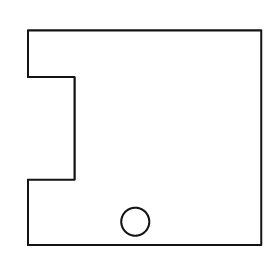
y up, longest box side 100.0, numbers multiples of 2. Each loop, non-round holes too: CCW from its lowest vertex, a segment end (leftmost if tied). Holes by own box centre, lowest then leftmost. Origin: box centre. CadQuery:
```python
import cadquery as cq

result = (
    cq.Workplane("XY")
    .moveTo(-50.0, -46.0)
    .lineTo(50.0, -46.0)
    .lineTo(50.0, 46.0)
    .lineTo(-50.0, 46.0)
    .lineTo(-50.0, 26.0)
    .lineTo(-30.0, 26.0)
    .lineTo(-30.0, -18.0)
    .lineTo(-50.0, -18.0)
    .close()
    .moveTo(-4.0, -36.0)
    .circle(6.0)
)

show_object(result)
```